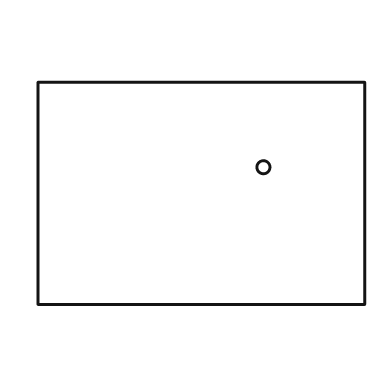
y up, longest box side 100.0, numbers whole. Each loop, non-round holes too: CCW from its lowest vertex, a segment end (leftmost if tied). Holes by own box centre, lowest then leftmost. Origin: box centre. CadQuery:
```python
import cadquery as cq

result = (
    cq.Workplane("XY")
    .moveTo(-50.0, -34.0)
    .lineTo(50.0, -34.0)
    .lineTo(50.0, 34.0)
    .lineTo(-50.0, 34.0)
    .close()
    .moveTo(19.0, 8.0)
    .circle(2.0)
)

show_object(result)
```